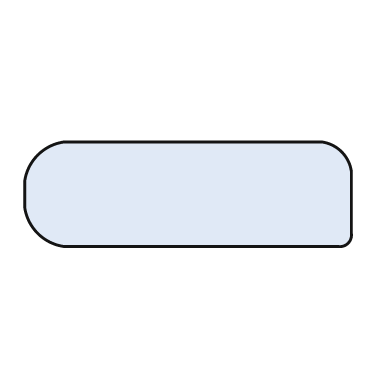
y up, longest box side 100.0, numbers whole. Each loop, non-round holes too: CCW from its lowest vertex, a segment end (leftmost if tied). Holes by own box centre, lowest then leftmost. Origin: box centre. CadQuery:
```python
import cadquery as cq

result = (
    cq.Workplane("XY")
    .moveTo(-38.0, -16.0)
    .lineTo(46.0, -16.0)
    .threePointArc((49.0, -15.0), (50.0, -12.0))
    .lineTo(50.0, 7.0)
    .threePointArc((47.0, 13.0), (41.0, 16.0))
    .lineTo(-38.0, 16.0)
    .threePointArc((-46.0, 12.0), (-50.0, 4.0))
    .lineTo(-50.0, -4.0)
    .threePointArc((-46.0, -12.0), (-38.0, -16.0))
    .close()
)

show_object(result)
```